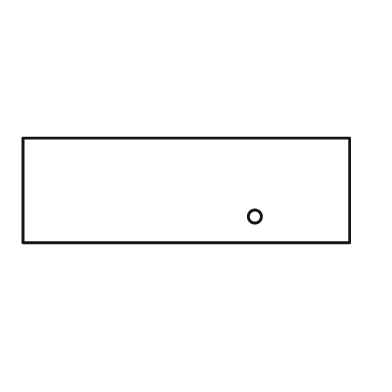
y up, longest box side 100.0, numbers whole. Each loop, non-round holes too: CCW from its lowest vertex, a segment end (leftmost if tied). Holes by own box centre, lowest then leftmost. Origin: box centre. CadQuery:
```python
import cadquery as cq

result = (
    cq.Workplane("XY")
    .moveTo(-50.0, -16.0)
    .lineTo(50.0, -16.0)
    .lineTo(50.0, 16.0)
    .lineTo(-50.0, 16.0)
    .close()
    .moveTo(21.0, -8.0)
    .circle(2.0)
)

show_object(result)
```